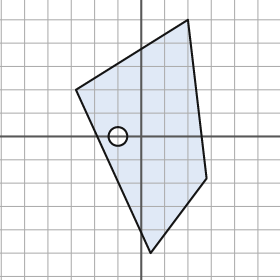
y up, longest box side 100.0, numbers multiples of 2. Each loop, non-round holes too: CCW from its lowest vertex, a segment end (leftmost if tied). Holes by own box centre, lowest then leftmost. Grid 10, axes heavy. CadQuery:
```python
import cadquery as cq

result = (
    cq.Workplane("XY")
    .moveTo(4.0, -50.0)
    .lineTo(28.0, -18.0)
    .lineTo(20.0, 50.0)
    .lineTo(-28.0, 20.0)
    .close()
    .moveTo(-10.0, 0.0)
    .circle(4.0)
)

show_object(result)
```